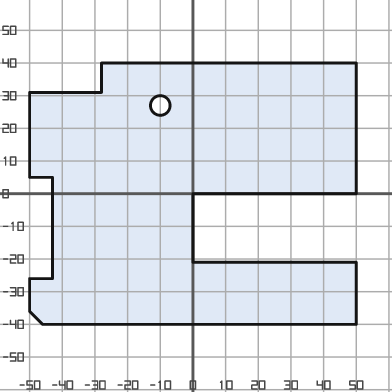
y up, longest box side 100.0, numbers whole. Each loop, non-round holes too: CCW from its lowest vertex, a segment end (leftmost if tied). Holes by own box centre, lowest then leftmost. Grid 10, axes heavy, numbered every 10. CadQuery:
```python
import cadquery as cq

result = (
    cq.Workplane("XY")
    .moveTo(-46.0, -40.0)
    .lineTo(50.0, -40.0)
    .lineTo(50.0, -21.0)
    .lineTo(0.0, -21.0)
    .lineTo(0.0, 0.0)
    .lineTo(50.0, 0.0)
    .lineTo(50.0, 40.0)
    .lineTo(-28.0, 40.0)
    .lineTo(-28.0, 31.0)
    .lineTo(-50.0, 31.0)
    .lineTo(-50.0, 5.0)
    .lineTo(-43.0, 5.0)
    .lineTo(-43.0, -26.0)
    .lineTo(-50.0, -26.0)
    .lineTo(-50.0, -36.0)
    .close()
    .moveTo(-10.0, 27.0)
    .circle(3.0)
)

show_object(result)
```